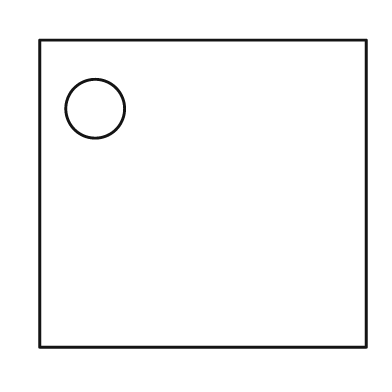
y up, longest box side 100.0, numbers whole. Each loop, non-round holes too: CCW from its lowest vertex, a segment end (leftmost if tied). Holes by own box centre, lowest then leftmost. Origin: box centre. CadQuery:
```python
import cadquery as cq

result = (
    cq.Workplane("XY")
    .moveTo(-50.0, -47.0)
    .lineTo(50.0, -47.0)
    .lineTo(50.0, 47.0)
    .lineTo(-50.0, 47.0)
    .close()
    .moveTo(-33.0, 26.0)
    .circle(9.0)
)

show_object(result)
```